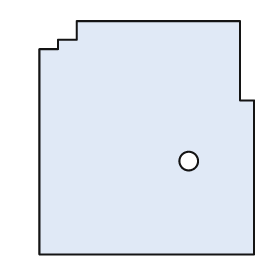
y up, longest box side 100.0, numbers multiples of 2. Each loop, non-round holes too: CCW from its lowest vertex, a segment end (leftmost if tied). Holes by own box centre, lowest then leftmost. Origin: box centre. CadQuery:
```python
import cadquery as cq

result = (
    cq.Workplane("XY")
    .moveTo(-46.0, -50.0)
    .lineTo(46.0, -50.0)
    .lineTo(46.0, 16.0)
    .lineTo(40.0, 16.0)
    .lineTo(40.0, 50.0)
    .lineTo(-30.0, 50.0)
    .lineTo(-30.0, 42.0)
    .lineTo(-38.0, 42.0)
    .lineTo(-38.0, 38.0)
    .lineTo(-46.0, 38.0)
    .close()
    .moveTo(18.0, -10.0)
    .circle(4.0)
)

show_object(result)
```